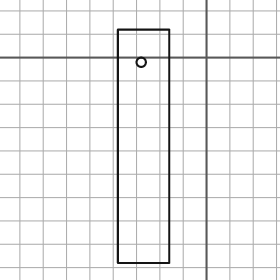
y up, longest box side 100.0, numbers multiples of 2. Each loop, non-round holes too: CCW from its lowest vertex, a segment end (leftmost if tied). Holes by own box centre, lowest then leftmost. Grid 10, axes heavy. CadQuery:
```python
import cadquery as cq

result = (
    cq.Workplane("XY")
    .moveTo(-38.0, -88.0)
    .lineTo(-16.0, -88.0)
    .lineTo(-16.0, 12.0)
    .lineTo(-38.0, 12.0)
    .close()
    .moveTo(-28.0, -2.0)
    .circle(2.0)
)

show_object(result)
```